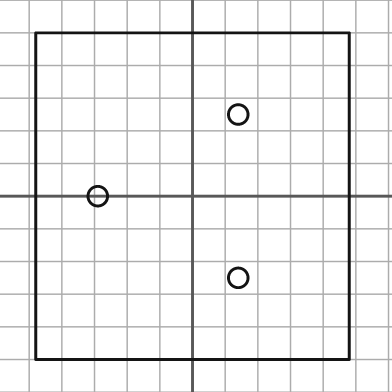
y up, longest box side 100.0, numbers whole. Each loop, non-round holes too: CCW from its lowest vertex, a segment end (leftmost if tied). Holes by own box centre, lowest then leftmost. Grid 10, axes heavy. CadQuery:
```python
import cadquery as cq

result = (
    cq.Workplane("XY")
    .moveTo(-48.0, -50.0)
    .lineTo(48.0, -50.0)
    .lineTo(48.0, 50.0)
    .lineTo(-48.0, 50.0)
    .close()
    .moveTo(14.0, -25.0)
    .circle(3.0)
    .moveTo(-29.0, 0.0)
    .circle(3.0)
    .moveTo(14.0, 25.0)
    .circle(3.0)
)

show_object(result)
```